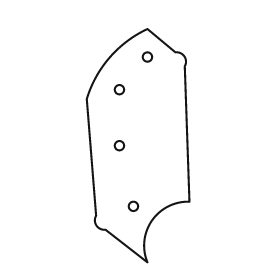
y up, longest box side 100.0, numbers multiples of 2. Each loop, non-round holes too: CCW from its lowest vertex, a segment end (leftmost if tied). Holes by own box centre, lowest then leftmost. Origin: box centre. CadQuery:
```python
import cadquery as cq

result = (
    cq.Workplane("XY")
    .moveTo(4.0, -50.0)
    .threePointArc((6.0, -32.0), (22.0, -24.0))
    .lineTo(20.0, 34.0)
    .threePointArc((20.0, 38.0), (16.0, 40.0))
    .lineTo(4.0, 50.0)
    .threePointArc((-12.0, 38.0), (-22.0, 20.0))
    .lineTo(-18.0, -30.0)
    .threePointArc((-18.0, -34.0), (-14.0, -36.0))
    .close()
    .moveTo(-2.0, -26.0)
    .circle(2.0)
    .moveTo(-8.0, 0.0)
    .circle(2.0)
    .moveTo(-8.0, 24.0)
    .circle(2.0)
    .moveTo(4.0, 38.0)
    .circle(2.0)
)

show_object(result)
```